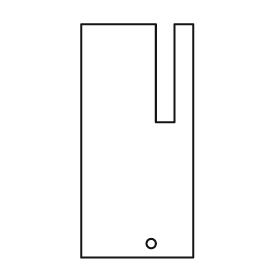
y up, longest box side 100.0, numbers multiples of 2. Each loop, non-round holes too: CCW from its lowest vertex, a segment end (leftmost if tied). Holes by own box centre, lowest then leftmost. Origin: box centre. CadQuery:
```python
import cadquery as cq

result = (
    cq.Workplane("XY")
    .moveTo(-24.0, -50.0)
    .lineTo(24.0, -50.0)
    .lineTo(24.0, 50.0)
    .lineTo(16.0, 50.0)
    .lineTo(16.0, 8.0)
    .lineTo(8.0, 8.0)
    .lineTo(8.0, 50.0)
    .lineTo(-24.0, 50.0)
    .close()
    .moveTo(6.0, -44.0)
    .circle(2.0)
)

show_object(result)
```